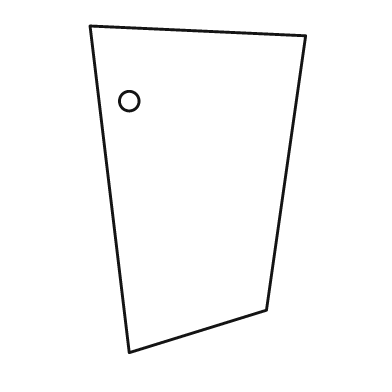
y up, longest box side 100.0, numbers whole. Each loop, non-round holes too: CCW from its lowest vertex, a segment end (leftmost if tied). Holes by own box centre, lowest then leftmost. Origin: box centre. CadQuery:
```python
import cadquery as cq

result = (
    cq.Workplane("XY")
    .moveTo(-21.0, -50.0)
    .lineTo(21.0, -37.0)
    .lineTo(33.0, 47.0)
    .lineTo(-33.0, 50.0)
    .close()
    .moveTo(-21.0, 27.0)
    .circle(3.0)
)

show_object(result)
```